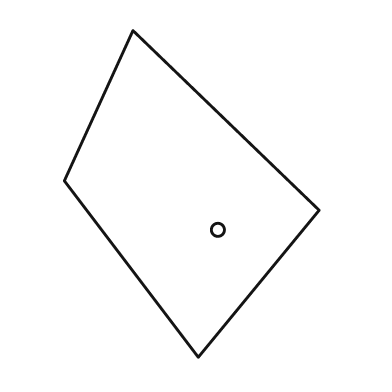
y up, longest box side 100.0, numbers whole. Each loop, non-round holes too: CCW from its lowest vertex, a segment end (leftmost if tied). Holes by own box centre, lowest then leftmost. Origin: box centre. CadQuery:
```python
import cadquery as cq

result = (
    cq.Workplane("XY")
    .moveTo(2.0, -50.0)
    .lineTo(39.0, -5.0)
    .lineTo(-18.0, 50.0)
    .lineTo(-39.0, 4.0)
    .close()
    .moveTo(8.0, -11.0)
    .circle(2.0)
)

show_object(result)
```